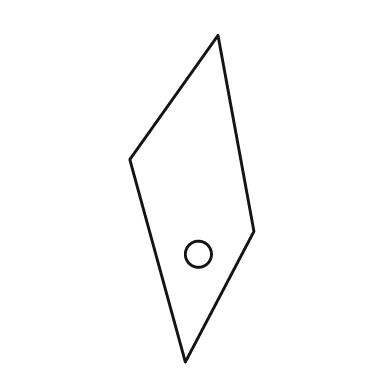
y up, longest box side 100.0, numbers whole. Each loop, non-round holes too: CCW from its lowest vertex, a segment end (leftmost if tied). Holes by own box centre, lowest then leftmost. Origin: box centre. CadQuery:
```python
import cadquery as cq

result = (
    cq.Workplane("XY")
    .moveTo(-2.0, -50.0)
    .lineTo(19.0, -10.0)
    .lineTo(8.0, 50.0)
    .lineTo(-19.0, 12.0)
    .close()
    .moveTo(2.0, -17.0)
    .circle(4.0)
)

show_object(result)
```